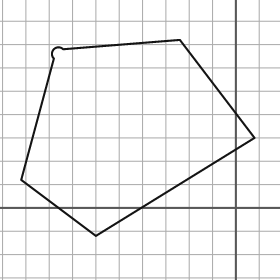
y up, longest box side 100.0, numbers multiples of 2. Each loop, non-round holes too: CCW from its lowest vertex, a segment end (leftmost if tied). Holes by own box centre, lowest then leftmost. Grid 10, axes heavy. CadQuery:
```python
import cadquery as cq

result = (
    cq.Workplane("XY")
    .moveTo(-60.0, -12.0)
    .lineTo(8.0, 30.0)
    .lineTo(-24.0, 72.0)
    .lineTo(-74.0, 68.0)
    .threePointArc((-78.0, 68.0), (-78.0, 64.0))
    .lineTo(-92.0, 12.0)
    .close()
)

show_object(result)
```